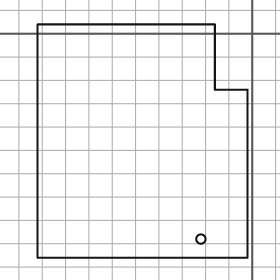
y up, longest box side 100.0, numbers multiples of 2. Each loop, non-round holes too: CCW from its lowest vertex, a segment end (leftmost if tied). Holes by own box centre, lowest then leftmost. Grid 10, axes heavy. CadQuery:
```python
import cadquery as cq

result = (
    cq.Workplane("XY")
    .moveTo(-92.0, -96.0)
    .lineTo(-2.0, -96.0)
    .lineTo(-2.0, -24.0)
    .lineTo(-16.0, -24.0)
    .lineTo(-16.0, 4.0)
    .lineTo(-92.0, 4.0)
    .close()
    .moveTo(-22.0, -88.0)
    .circle(2.0)
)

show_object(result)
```